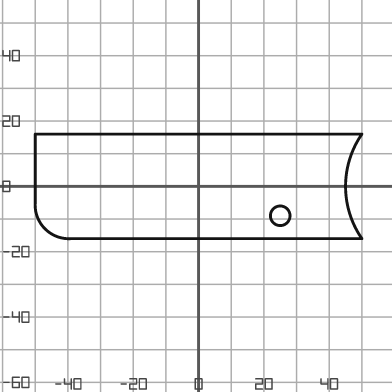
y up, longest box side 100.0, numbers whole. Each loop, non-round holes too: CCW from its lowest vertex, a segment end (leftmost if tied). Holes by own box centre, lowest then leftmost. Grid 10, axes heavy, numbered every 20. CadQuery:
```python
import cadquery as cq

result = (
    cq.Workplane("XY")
    .moveTo(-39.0, -16.0)
    .lineTo(50.0, -16.0)
    .threePointArc((45.0, 0.0), (50.0, 16.0))
    .lineTo(-50.0, 16.0)
    .lineTo(-50.0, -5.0)
    .threePointArc((-47.0, -13.0), (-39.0, -16.0))
    .close()
    .moveTo(25.0, -9.0)
    .circle(3.0)
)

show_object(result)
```